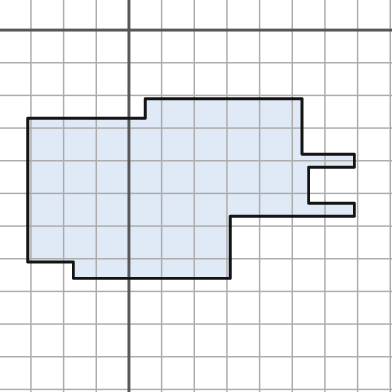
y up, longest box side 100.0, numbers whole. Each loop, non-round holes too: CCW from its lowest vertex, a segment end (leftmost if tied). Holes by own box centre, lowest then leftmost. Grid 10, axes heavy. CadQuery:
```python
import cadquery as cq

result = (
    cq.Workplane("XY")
    .moveTo(-17.0, -76.0)
    .lineTo(31.0, -76.0)
    .lineTo(31.0, -57.0)
    .lineTo(69.0, -57.0)
    .lineTo(69.0, -53.0)
    .lineTo(55.0, -53.0)
    .lineTo(55.0, -42.0)
    .lineTo(69.0, -42.0)
    .lineTo(69.0, -38.0)
    .lineTo(53.0, -38.0)
    .lineTo(53.0, -21.0)
    .lineTo(5.0, -21.0)
    .lineTo(5.0, -27.0)
    .lineTo(-31.0, -27.0)
    .lineTo(-31.0, -71.0)
    .lineTo(-17.0, -71.0)
    .close()
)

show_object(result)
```